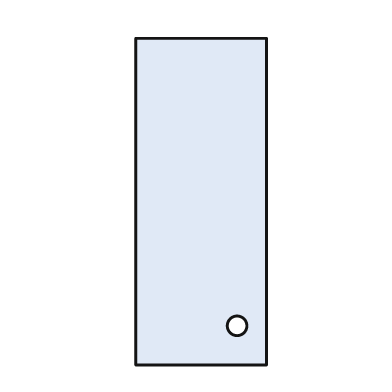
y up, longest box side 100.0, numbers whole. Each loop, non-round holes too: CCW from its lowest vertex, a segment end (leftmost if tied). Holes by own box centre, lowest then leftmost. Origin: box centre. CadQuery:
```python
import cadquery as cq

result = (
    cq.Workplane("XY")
    .moveTo(-20.0, -50.0)
    .lineTo(20.0, -50.0)
    .lineTo(20.0, 50.0)
    .lineTo(-20.0, 50.0)
    .close()
    .moveTo(11.0, -38.0)
    .circle(3.0)
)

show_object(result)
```